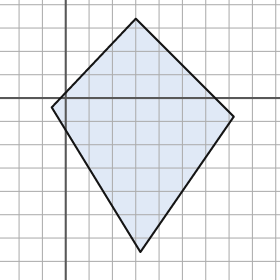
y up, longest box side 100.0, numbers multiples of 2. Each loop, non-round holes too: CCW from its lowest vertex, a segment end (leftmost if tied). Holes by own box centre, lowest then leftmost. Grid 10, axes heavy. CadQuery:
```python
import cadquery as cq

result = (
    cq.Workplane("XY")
    .moveTo(32.0, -66.0)
    .lineTo(72.0, -8.0)
    .lineTo(30.0, 34.0)
    .lineTo(-6.0, -4.0)
    .close()
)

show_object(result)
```